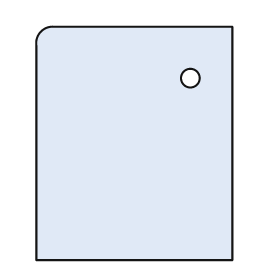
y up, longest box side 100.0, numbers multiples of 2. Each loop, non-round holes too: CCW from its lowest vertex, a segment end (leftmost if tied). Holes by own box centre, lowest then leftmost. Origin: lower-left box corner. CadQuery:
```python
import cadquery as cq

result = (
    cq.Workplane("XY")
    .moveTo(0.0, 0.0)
    .lineTo(84.0, 0.0)
    .lineTo(84.0, 100.0)
    .lineTo(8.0, 100.0)
    .threePointArc((2.0, 98.0), (0.0, 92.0))
    .close()
    .moveTo(66.0, 78.0)
    .circle(4.0)
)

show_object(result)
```